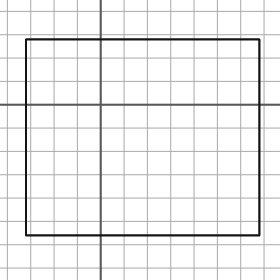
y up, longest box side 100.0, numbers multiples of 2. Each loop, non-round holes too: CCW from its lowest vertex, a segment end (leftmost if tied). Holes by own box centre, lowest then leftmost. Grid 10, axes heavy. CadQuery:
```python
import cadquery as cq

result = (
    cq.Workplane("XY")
    .moveTo(-32.0, -56.0)
    .lineTo(68.0, -56.0)
    .lineTo(68.0, 28.0)
    .lineTo(-32.0, 28.0)
    .close()
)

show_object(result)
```